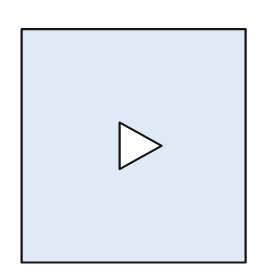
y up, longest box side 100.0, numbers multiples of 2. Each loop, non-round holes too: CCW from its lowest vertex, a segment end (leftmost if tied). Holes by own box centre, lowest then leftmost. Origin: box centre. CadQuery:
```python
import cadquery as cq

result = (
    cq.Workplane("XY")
    .moveTo(-48.0, -50.0)
    .lineTo(48.0, -50.0)
    .lineTo(48.0, 50.0)
    .lineTo(-48.0, 50.0)
    .close()
    .moveTo(-6.0, -10.0)
    .lineTo(12.0, 0.0)
    .lineTo(-6.0, 10.0)
    .close()
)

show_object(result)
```